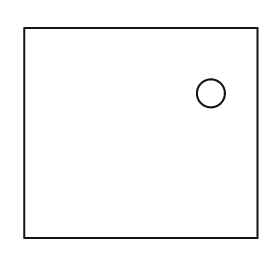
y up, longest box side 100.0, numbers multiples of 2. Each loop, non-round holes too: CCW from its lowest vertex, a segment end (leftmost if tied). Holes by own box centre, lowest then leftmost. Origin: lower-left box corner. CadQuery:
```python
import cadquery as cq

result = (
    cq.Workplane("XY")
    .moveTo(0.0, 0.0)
    .lineTo(100.0, 0.0)
    .lineTo(100.0, 90.0)
    .lineTo(0.0, 90.0)
    .close()
    .moveTo(80.0, 62.0)
    .circle(6.0)
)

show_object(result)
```